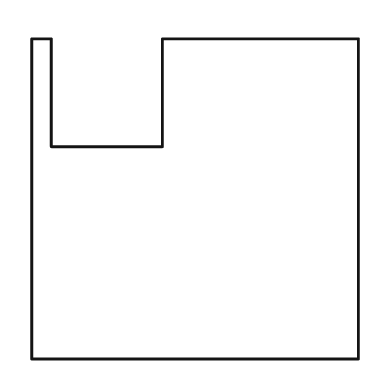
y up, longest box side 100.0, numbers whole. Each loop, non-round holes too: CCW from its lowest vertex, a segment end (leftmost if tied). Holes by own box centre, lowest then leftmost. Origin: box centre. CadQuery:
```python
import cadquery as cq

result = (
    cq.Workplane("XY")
    .moveTo(-50.0, -49.0)
    .lineTo(50.0, -49.0)
    .lineTo(50.0, 49.0)
    .lineTo(-10.0, 49.0)
    .lineTo(-10.0, 16.0)
    .lineTo(-44.0, 16.0)
    .lineTo(-44.0, 49.0)
    .lineTo(-50.0, 49.0)
    .close()
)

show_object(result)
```